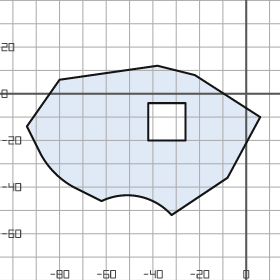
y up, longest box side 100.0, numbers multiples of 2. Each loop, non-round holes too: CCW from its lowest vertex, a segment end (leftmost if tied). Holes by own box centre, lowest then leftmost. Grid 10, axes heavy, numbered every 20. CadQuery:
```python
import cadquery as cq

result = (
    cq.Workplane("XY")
    .moveTo(-32.0, -52.0)
    .lineTo(-8.0, -36.0)
    .lineTo(6.0, -10.0)
    .lineTo(-22.0, 8.0)
    .lineTo(-38.0, 12.0)
    .lineTo(-80.0, 6.0)
    .lineTo(-94.0, -14.0)
    .lineTo(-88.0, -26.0)
    .threePointArc((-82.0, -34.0), (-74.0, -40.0))
    .lineTo(-62.0, -46.0)
    .threePointArc((-46.0, -44.0), (-32.0, -52.0))
    .close()
    .moveTo(-42.0, -20.0)
    .lineTo(-26.0, -20.0)
    .lineTo(-26.0, -4.0)
    .lineTo(-42.0, -4.0)
    .close()
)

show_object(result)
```